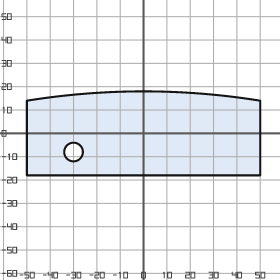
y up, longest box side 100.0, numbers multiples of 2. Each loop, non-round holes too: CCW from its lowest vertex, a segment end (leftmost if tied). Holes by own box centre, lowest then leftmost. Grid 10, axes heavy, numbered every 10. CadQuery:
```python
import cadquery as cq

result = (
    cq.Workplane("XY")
    .moveTo(-50.0, -18.0)
    .lineTo(50.0, -18.0)
    .lineTo(50.0, 14.0)
    .threePointArc((0.0, 18.0), (-50.0, 14.0))
    .close()
    .moveTo(-30.0, -8.0)
    .circle(4.0)
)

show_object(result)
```